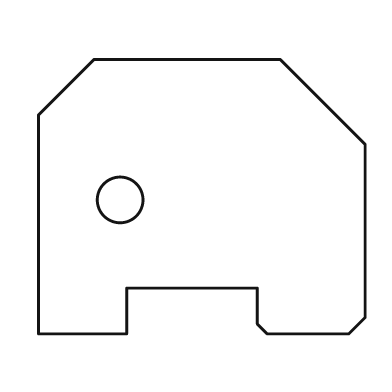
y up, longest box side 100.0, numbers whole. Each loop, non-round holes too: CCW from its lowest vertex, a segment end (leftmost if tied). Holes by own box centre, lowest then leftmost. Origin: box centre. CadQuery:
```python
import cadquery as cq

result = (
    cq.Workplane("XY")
    .moveTo(-50.0, -42.0)
    .lineTo(-23.0, -42.0)
    .lineTo(-23.0, -28.0)
    .lineTo(17.0, -28.0)
    .lineTo(17.0, -39.0)
    .lineTo(20.0, -42.0)
    .lineTo(45.0, -42.0)
    .lineTo(50.0, -37.0)
    .lineTo(50.0, 16.0)
    .lineTo(24.0, 42.0)
    .lineTo(-33.0, 42.0)
    .lineTo(-50.0, 25.0)
    .close()
    .moveTo(-25.0, -1.0)
    .circle(7.0)
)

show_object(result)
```